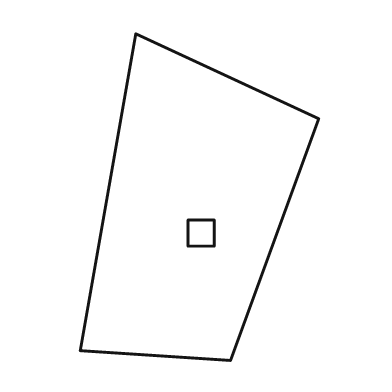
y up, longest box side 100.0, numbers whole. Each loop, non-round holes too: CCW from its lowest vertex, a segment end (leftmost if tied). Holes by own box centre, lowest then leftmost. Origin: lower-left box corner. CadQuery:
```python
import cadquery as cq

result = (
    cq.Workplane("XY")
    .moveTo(46.0, 0.0)
    .lineTo(73.0, 74.0)
    .lineTo(17.0, 100.0)
    .lineTo(0.0, 3.0)
    .close()
    .moveTo(33.0, 35.0)
    .lineTo(41.0, 35.0)
    .lineTo(41.0, 43.0)
    .lineTo(33.0, 43.0)
    .close()
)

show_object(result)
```